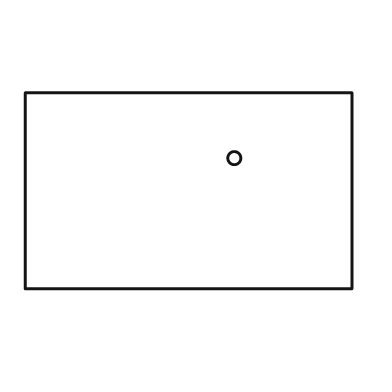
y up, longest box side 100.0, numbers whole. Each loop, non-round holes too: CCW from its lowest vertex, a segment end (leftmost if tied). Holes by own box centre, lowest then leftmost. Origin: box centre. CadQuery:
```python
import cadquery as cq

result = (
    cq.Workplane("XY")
    .moveTo(-50.0, -30.0)
    .lineTo(50.0, -30.0)
    .lineTo(50.0, 30.0)
    .lineTo(-50.0, 30.0)
    .close()
    .moveTo(14.0, 10.0)
    .circle(2.0)
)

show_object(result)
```